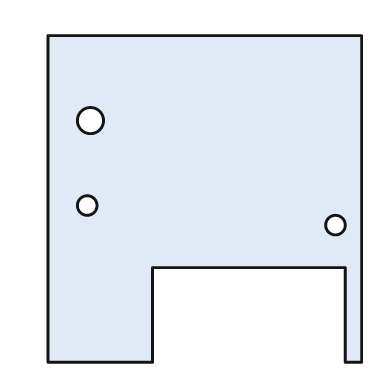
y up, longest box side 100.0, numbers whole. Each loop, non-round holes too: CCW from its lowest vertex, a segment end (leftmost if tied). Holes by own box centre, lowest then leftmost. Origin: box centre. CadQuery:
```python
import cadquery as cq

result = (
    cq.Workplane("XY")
    .moveTo(-48.0, -50.0)
    .lineTo(-16.0, -50.0)
    .lineTo(-16.0, -21.0)
    .lineTo(43.0, -21.0)
    .lineTo(43.0, -50.0)
    .lineTo(48.0, -50.0)
    .lineTo(48.0, 50.0)
    .lineTo(-48.0, 50.0)
    .close()
    .moveTo(40.0, -8.0)
    .circle(3.0)
    .moveTo(-36.0, -2.0)
    .circle(3.0)
    .moveTo(-35.0, 24.0)
    .circle(4.0)
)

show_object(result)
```